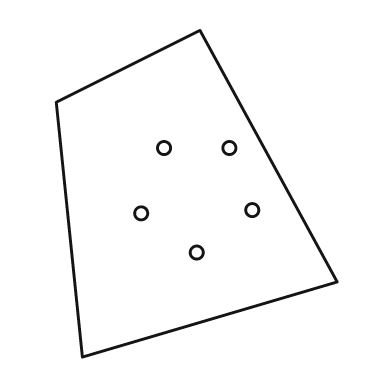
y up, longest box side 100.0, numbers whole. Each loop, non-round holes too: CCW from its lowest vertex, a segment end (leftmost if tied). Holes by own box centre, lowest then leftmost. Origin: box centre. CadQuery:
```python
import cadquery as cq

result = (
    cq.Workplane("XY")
    .moveTo(-35.0, -50.0)
    .lineTo(43.0, -27.0)
    .lineTo(1.0, 50.0)
    .lineTo(-43.0, 28.0)
    .close()
    .moveTo(0.0, -18.0)
    .circle(2.0)
    .moveTo(-17.0, -6.0)
    .circle(2.0)
    .moveTo(17.0, -5.0)
    .circle(2.0)
    .moveTo(-10.0, 14.0)
    .circle(2.0)
    .moveTo(10.0, 14.0)
    .circle(2.0)
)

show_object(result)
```